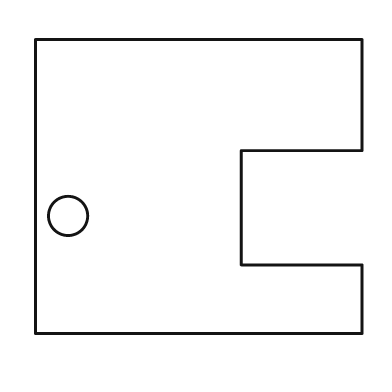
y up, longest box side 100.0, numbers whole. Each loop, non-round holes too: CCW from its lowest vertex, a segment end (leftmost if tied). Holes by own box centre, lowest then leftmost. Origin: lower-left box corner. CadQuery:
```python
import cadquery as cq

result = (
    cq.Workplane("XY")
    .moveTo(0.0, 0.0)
    .lineTo(100.0, 0.0)
    .lineTo(100.0, 21.0)
    .lineTo(63.0, 21.0)
    .lineTo(63.0, 56.0)
    .lineTo(100.0, 56.0)
    .lineTo(100.0, 90.0)
    .lineTo(0.0, 90.0)
    .close()
    .moveTo(10.0, 36.0)
    .circle(6.0)
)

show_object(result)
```